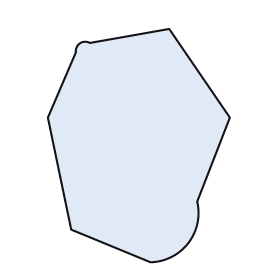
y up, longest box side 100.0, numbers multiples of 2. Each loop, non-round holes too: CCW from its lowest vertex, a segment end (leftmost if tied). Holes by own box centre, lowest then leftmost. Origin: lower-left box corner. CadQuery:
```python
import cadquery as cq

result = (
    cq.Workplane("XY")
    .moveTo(44.0, 0.0)
    .threePointArc((60.0, 8.0), (64.0, 26.0))
    .lineTo(78.0, 62.0)
    .lineTo(52.0, 100.0)
    .lineTo(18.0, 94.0)
    .threePointArc((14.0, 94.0), (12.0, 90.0))
    .lineTo(0.0, 62.0)
    .lineTo(10.0, 14.0)
    .close()
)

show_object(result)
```